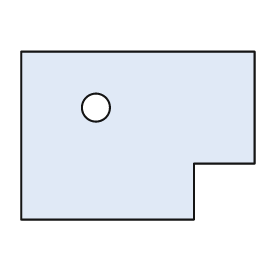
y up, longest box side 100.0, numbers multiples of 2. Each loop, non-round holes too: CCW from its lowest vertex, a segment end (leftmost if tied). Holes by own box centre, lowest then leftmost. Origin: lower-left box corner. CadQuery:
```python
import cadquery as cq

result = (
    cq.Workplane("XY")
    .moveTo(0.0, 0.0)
    .lineTo(74.0, 0.0)
    .lineTo(74.0, 24.0)
    .lineTo(100.0, 24.0)
    .lineTo(100.0, 72.0)
    .lineTo(0.0, 72.0)
    .close()
    .moveTo(32.0, 48.0)
    .circle(6.0)
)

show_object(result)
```